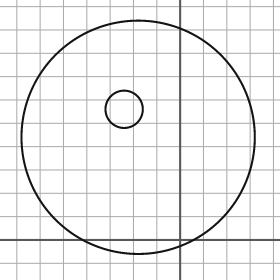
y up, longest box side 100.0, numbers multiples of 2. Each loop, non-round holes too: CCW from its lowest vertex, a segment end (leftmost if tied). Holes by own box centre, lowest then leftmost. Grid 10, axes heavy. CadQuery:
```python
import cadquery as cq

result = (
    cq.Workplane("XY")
    .moveTo(-18.0, 44.0)
    .circle(50.0)
    .moveTo(-24.0, 56.0)
    .circle(8.0)
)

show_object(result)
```